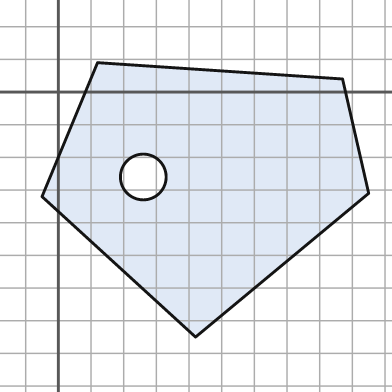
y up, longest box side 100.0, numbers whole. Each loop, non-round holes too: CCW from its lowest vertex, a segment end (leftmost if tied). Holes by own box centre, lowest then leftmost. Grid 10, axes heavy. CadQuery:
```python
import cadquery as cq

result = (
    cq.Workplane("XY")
    .moveTo(42.0, -75.0)
    .lineTo(95.0, -31.0)
    .lineTo(87.0, 4.0)
    .lineTo(12.0, 9.0)
    .lineTo(-5.0, -32.0)
    .close()
    .moveTo(26.0, -26.0)
    .circle(7.0)
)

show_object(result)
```